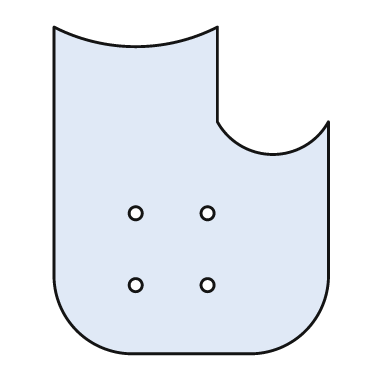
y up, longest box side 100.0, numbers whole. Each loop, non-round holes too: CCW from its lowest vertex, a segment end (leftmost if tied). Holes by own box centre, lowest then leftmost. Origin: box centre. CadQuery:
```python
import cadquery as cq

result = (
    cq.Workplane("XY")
    .moveTo(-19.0, -50.0)
    .lineTo(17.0, -50.0)
    .threePointArc((35.0, -43.0), (42.0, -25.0))
    .lineTo(42.0, 21.0)
    .threePointArc((25.0, 11.0), (8.0, 21.0))
    .lineTo(8.0, 50.0)
    .threePointArc((-17.0, 44.0), (-42.0, 50.0))
    .lineTo(-42.0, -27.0)
    .threePointArc((-35.0, -43.0), (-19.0, -50.0))
    .close()
    .moveTo(-17.0, -29.0)
    .circle(2.0)
    .moveTo(5.0, -29.0)
    .circle(2.0)
    .moveTo(-17.0, -7.0)
    .circle(2.0)
    .moveTo(5.0, -7.0)
    .circle(2.0)
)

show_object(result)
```